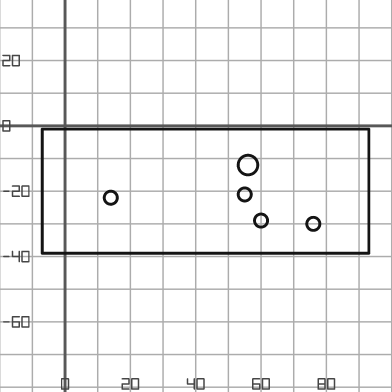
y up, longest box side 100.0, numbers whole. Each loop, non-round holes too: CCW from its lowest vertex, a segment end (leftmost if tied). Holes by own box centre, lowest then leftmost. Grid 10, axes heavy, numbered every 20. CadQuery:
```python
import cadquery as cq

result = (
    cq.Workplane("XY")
    .moveTo(-7.0, -39.0)
    .lineTo(93.0, -39.0)
    .lineTo(93.0, -1.0)
    .lineTo(-7.0, -1.0)
    .close()
    .moveTo(76.0, -30.0)
    .circle(2.0)
    .moveTo(60.0, -29.0)
    .circle(2.0)
    .moveTo(14.0, -22.0)
    .circle(2.0)
    .moveTo(55.0, -21.0)
    .circle(2.0)
    .moveTo(56.0, -12.0)
    .circle(3.0)
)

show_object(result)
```